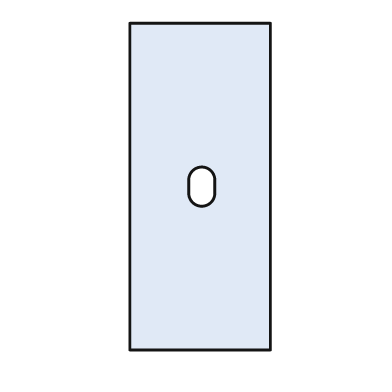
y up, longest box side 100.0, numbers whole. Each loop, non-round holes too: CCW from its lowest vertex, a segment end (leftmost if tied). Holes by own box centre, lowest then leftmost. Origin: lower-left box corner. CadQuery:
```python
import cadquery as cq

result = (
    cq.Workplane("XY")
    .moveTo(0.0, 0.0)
    .lineTo(43.0, 0.0)
    .lineTo(43.0, 100.0)
    .lineTo(0.0, 100.0)
    .close()
    .moveTo(18.0, 48.0)
    .threePointArc((22.0, 44.0), (26.0, 48.0))
    .lineTo(26.0, 52.0)
    .threePointArc((22.0, 56.0), (18.0, 52.0))
    .close()
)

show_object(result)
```